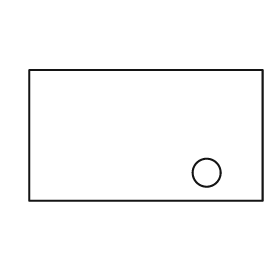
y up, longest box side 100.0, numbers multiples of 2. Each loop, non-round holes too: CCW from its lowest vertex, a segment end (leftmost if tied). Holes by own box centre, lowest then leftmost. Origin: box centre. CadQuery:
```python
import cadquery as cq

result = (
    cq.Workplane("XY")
    .moveTo(-50.0, -28.0)
    .lineTo(50.0, -28.0)
    .lineTo(50.0, 28.0)
    .lineTo(-50.0, 28.0)
    .close()
    .moveTo(26.0, -16.0)
    .circle(6.0)
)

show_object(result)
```